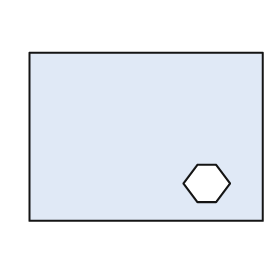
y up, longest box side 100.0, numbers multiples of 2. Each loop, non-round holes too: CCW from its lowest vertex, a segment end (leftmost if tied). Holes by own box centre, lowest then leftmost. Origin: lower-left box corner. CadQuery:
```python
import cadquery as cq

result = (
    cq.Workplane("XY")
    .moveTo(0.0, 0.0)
    .lineTo(100.0, 0.0)
    .lineTo(100.0, 72.0)
    .lineTo(0.0, 72.0)
    .close()
    .moveTo(72.0, 8.0)
    .lineTo(80.0, 8.0)
    .lineTo(86.0, 16.0)
    .lineTo(80.0, 24.0)
    .lineTo(72.0, 24.0)
    .lineTo(66.0, 16.0)
    .close()
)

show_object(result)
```